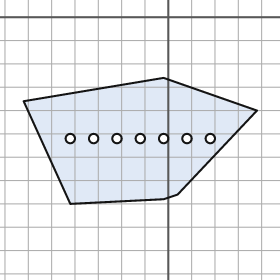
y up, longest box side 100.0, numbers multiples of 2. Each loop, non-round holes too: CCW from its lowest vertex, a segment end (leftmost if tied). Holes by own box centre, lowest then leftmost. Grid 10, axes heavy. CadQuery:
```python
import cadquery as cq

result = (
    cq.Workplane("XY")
    .moveTo(-42.0, -80.0)
    .lineTo(-2.0, -78.0)
    .lineTo(4.0, -76.0)
    .lineTo(38.0, -40.0)
    .lineTo(-2.0, -26.0)
    .lineTo(-62.0, -36.0)
    .close()
    .moveTo(-42.0, -52.0)
    .circle(2.0)
    .moveTo(-32.0, -52.0)
    .circle(2.0)
    .moveTo(-22.0, -52.0)
    .circle(2.0)
    .moveTo(-12.0, -52.0)
    .circle(2.0)
    .moveTo(-2.0, -52.0)
    .circle(2.0)
    .moveTo(8.0, -52.0)
    .circle(2.0)
    .moveTo(18.0, -52.0)
    .circle(2.0)
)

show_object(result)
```